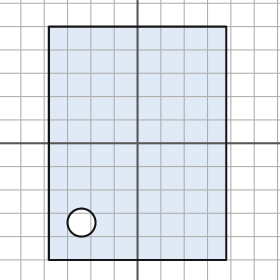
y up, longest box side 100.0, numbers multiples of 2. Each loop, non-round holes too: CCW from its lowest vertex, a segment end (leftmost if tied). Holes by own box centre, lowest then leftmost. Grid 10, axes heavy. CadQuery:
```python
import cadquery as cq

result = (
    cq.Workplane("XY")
    .moveTo(-38.0, -50.0)
    .lineTo(38.0, -50.0)
    .lineTo(38.0, 50.0)
    .lineTo(-38.0, 50.0)
    .close()
    .moveTo(-24.0, -34.0)
    .circle(6.0)
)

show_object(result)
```